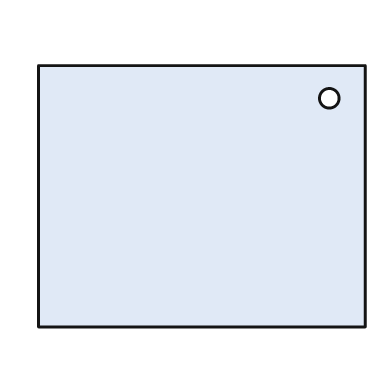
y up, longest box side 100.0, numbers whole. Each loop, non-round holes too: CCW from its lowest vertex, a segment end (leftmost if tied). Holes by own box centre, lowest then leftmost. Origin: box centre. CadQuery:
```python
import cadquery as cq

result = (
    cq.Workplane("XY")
    .moveTo(-50.0, -40.0)
    .lineTo(50.0, -40.0)
    .lineTo(50.0, 40.0)
    .lineTo(-50.0, 40.0)
    .close()
    .moveTo(39.0, 30.0)
    .circle(3.0)
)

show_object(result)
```